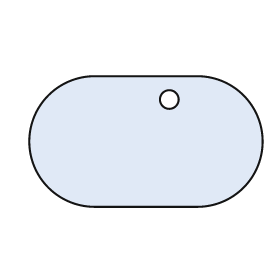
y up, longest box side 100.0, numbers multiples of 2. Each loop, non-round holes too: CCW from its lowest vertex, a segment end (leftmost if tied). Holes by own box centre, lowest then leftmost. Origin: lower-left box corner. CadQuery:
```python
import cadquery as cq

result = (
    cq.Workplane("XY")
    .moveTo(28.0, 0.0)
    .lineTo(72.0, 0.0)
    .threePointArc((100.0, 28.0), (72.0, 56.0))
    .lineTo(28.0, 56.0)
    .threePointArc((0.0, 28.0), (28.0, 0.0))
    .close()
    .moveTo(60.0, 46.0)
    .circle(4.0)
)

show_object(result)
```